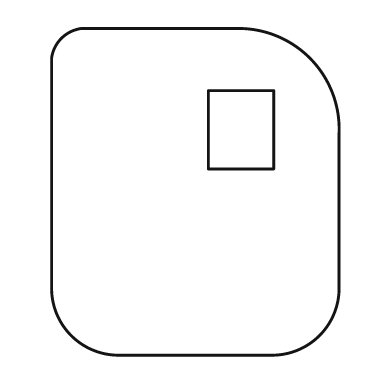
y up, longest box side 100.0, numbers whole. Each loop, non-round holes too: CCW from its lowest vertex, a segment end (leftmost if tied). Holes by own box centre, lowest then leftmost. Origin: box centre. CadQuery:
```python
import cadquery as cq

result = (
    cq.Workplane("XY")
    .moveTo(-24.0, -50.0)
    .lineTo(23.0, -50.0)
    .threePointArc((38.0, -44.0), (44.0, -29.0))
    .lineTo(44.0, 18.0)
    .threePointArc((35.0, 41.0), (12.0, 50.0))
    .lineTo(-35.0, 50.0)
    .threePointArc((-41.0, 47.0), (-44.0, 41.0))
    .lineTo(-44.0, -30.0)
    .threePointArc((-38.0, -44.0), (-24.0, -50.0))
    .close()
    .moveTo(4.0, 7.0)
    .lineTo(24.0, 7.0)
    .lineTo(24.0, 31.0)
    .lineTo(4.0, 31.0)
    .close()
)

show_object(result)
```